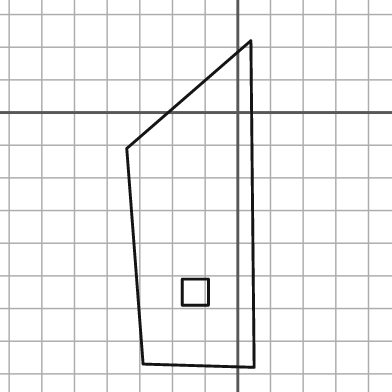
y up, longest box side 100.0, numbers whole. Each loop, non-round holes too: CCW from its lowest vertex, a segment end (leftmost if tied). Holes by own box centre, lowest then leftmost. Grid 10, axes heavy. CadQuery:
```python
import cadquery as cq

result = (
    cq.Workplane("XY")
    .moveTo(5.0, -78.0)
    .lineTo(4.0, 22.0)
    .lineTo(-34.0, -11.0)
    .lineTo(-29.0, -77.0)
    .close()
    .moveTo(-17.0, -59.0)
    .lineTo(-9.0, -59.0)
    .lineTo(-9.0, -51.0)
    .lineTo(-17.0, -51.0)
    .close()
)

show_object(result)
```